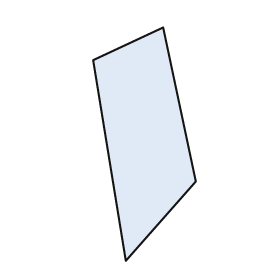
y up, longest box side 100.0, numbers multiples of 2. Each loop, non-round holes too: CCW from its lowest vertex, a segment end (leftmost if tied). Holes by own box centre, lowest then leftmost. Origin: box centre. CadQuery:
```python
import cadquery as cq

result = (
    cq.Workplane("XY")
    .moveTo(-8.0, -50.0)
    .lineTo(22.0, -16.0)
    .lineTo(8.0, 50.0)
    .lineTo(-22.0, 36.0)
    .close()
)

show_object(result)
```